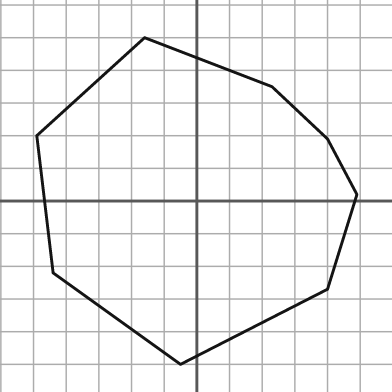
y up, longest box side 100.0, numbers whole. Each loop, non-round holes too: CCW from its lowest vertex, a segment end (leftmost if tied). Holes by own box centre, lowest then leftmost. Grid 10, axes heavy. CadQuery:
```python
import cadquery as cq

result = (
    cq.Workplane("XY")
    .moveTo(-5.0, -50.0)
    .lineTo(40.0, -27.0)
    .lineTo(49.0, 2.0)
    .lineTo(40.0, 19.0)
    .lineTo(23.0, 35.0)
    .lineTo(-16.0, 50.0)
    .lineTo(-49.0, 20.0)
    .lineTo(-44.0, -22.0)
    .close()
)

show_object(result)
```